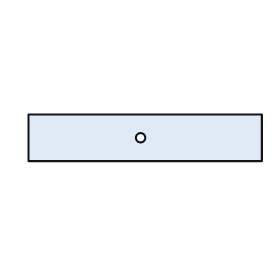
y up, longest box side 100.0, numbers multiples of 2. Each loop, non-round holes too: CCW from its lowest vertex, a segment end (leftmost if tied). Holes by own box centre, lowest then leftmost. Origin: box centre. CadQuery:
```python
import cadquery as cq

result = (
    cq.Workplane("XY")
    .moveTo(-50.0, -10.0)
    .lineTo(50.0, -10.0)
    .lineTo(50.0, 10.0)
    .lineTo(-50.0, 10.0)
    .close()
    .moveTo(-2.0, 0.0)
    .circle(2.0)
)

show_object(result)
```